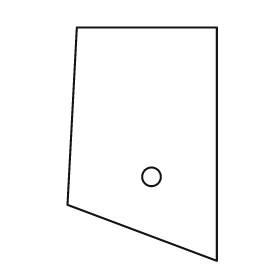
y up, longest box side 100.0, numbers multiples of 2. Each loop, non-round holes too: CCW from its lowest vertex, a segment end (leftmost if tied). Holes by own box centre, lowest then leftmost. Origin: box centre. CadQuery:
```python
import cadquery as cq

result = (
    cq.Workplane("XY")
    .moveTo(32.0, -50.0)
    .lineTo(32.0, 50.0)
    .lineTo(-28.0, 50.0)
    .lineTo(-32.0, -26.0)
    .close()
    .moveTo(4.0, -14.0)
    .circle(4.0)
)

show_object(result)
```